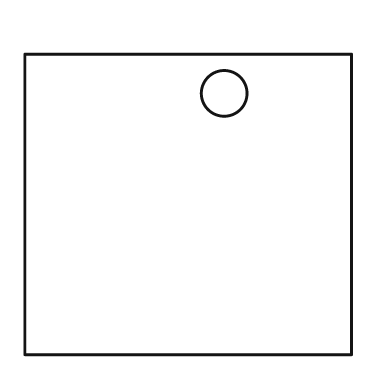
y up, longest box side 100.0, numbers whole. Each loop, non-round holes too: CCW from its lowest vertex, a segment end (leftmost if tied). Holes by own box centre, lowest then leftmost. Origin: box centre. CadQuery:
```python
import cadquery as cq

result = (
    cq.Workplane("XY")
    .moveTo(-50.0, -46.0)
    .lineTo(50.0, -46.0)
    .lineTo(50.0, 46.0)
    .lineTo(-50.0, 46.0)
    .close()
    .moveTo(11.0, 34.0)
    .circle(7.0)
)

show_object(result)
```